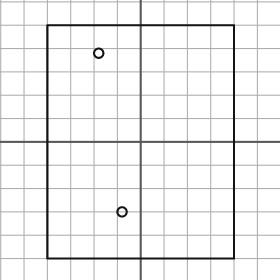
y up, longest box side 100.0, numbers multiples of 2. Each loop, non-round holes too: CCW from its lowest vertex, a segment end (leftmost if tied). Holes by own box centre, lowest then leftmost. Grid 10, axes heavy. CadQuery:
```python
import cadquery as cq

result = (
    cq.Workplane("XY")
    .moveTo(-40.0, -50.0)
    .lineTo(40.0, -50.0)
    .lineTo(40.0, 50.0)
    .lineTo(-40.0, 50.0)
    .close()
    .moveTo(-8.0, -30.0)
    .circle(2.0)
    .moveTo(-18.0, 38.0)
    .circle(2.0)
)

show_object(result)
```